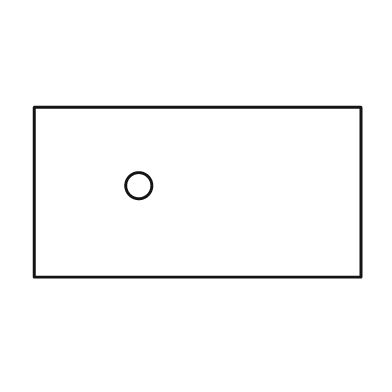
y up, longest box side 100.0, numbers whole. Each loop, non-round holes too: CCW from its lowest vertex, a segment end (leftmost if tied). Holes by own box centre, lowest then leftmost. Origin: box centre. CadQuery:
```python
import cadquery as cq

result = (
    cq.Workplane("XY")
    .moveTo(-50.0, -26.0)
    .lineTo(50.0, -26.0)
    .lineTo(50.0, 26.0)
    .lineTo(-50.0, 26.0)
    .close()
    .moveTo(-18.0, 2.0)
    .circle(4.0)
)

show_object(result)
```